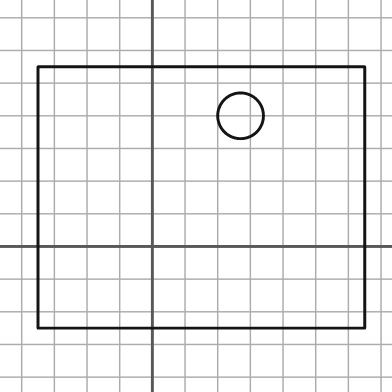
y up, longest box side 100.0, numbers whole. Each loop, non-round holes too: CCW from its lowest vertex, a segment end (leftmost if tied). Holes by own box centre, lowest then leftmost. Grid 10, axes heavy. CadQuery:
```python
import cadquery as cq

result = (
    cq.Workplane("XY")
    .moveTo(-35.0, -25.0)
    .lineTo(65.0, -25.0)
    .lineTo(65.0, 55.0)
    .lineTo(-35.0, 55.0)
    .close()
    .moveTo(27.0, 40.0)
    .circle(7.0)
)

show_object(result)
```